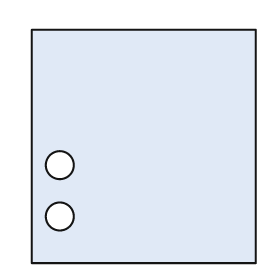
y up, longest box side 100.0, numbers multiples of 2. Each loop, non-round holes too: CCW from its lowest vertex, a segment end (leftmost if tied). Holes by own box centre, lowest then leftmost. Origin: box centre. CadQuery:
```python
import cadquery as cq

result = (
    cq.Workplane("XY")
    .moveTo(-48.0, -50.0)
    .lineTo(48.0, -50.0)
    .lineTo(48.0, 50.0)
    .lineTo(-48.0, 50.0)
    .close()
    .moveTo(-36.0, -30.0)
    .circle(6.0)
    .moveTo(-36.0, -8.0)
    .circle(6.0)
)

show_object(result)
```